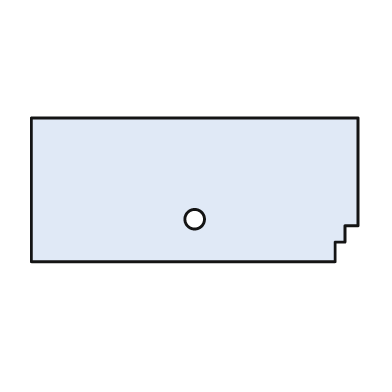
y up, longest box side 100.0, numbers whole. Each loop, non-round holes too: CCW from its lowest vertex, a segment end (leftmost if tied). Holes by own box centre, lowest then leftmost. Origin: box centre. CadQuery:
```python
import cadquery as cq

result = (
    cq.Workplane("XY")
    .moveTo(-50.0, -22.0)
    .lineTo(43.0, -22.0)
    .lineTo(43.0, -16.0)
    .lineTo(46.0, -16.0)
    .lineTo(46.0, -11.0)
    .lineTo(50.0, -11.0)
    .lineTo(50.0, 22.0)
    .lineTo(-50.0, 22.0)
    .close()
    .moveTo(0.0, -9.0)
    .circle(3.0)
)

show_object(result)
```